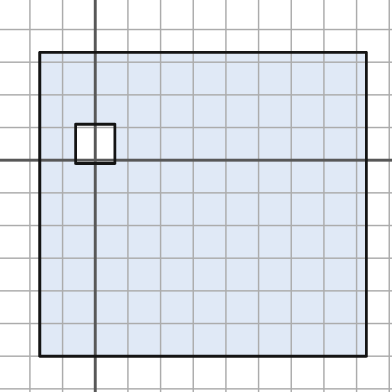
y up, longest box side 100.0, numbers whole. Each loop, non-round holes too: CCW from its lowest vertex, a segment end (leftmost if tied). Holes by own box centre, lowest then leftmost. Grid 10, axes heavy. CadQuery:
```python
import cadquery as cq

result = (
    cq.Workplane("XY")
    .moveTo(-17.0, -60.0)
    .lineTo(83.0, -60.0)
    .lineTo(83.0, 33.0)
    .lineTo(-17.0, 33.0)
    .close()
    .moveTo(-6.0, -1.0)
    .lineTo(6.0, -1.0)
    .lineTo(6.0, 11.0)
    .lineTo(-6.0, 11.0)
    .close()
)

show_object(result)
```